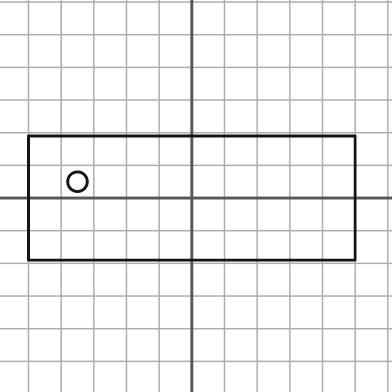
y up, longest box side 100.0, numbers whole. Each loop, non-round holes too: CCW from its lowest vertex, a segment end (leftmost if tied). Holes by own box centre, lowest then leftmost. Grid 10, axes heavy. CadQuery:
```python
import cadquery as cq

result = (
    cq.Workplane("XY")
    .moveTo(-50.0, -19.0)
    .lineTo(50.0, -19.0)
    .lineTo(50.0, 19.0)
    .lineTo(-50.0, 19.0)
    .close()
    .moveTo(-35.0, 5.0)
    .circle(3.0)
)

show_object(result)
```